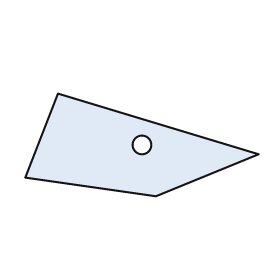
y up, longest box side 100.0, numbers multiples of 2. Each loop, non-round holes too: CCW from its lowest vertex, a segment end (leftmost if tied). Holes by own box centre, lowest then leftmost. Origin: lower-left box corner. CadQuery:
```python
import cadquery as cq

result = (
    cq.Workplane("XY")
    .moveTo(56.0, 0.0)
    .lineTo(100.0, 18.0)
    .lineTo(14.0, 44.0)
    .lineTo(0.0, 8.0)
    .close()
    .moveTo(50.0, 22.0)
    .circle(4.0)
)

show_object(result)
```